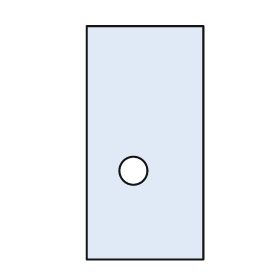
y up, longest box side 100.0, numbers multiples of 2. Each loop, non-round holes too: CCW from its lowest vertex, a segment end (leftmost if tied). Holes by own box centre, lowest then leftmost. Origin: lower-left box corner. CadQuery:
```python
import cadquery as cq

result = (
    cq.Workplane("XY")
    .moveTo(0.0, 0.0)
    .lineTo(50.0, 0.0)
    .lineTo(50.0, 100.0)
    .lineTo(0.0, 100.0)
    .close()
    .moveTo(20.0, 38.0)
    .circle(6.0)
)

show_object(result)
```